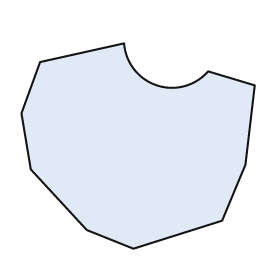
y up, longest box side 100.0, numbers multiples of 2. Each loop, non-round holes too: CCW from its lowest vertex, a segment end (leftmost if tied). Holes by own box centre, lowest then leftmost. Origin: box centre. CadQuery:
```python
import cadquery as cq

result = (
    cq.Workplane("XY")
    .moveTo(-2.0, -44.0)
    .lineTo(36.0, -32.0)
    .lineTo(46.0, -8.0)
    .lineTo(50.0, 26.0)
    .lineTo(30.0, 32.0)
    .threePointArc((8.0, 26.0), (-6.0, 44.0))
    .lineTo(-42.0, 36.0)
    .lineTo(-50.0, 14.0)
    .lineTo(-46.0, -10.0)
    .lineTo(-22.0, -36.0)
    .close()
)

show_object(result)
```